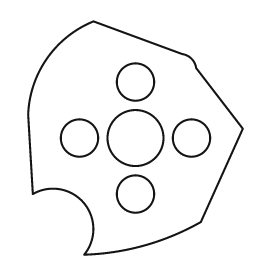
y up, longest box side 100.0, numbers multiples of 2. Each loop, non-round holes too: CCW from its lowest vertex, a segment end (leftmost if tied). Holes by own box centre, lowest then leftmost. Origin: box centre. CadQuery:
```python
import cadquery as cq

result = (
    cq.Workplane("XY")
    .moveTo(-22.0, -50.0)
    .threePointArc((4.0, -46.0), (28.0, -36.0))
    .lineTo(46.0, 4.0)
    .lineTo(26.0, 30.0)
    .threePointArc((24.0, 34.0), (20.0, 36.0))
    .lineTo(-18.0, 50.0)
    .threePointArc((-38.0, 34.0), (-46.0, 10.0))
    .lineTo(-44.0, -24.0)
    .threePointArc((-22.0, -28.0), (-22.0, -50.0))
    .close()
    .moveTo(0.0, -24.0)
    .circle(8.0)
    .moveTo(-24.0, 0.0)
    .circle(8.0)
    .moveTo(0.0, 0.0)
    .circle(12.0)
    .moveTo(24.0, 0.0)
    .circle(8.0)
    .moveTo(0.0, 24.0)
    .circle(8.0)
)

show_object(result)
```